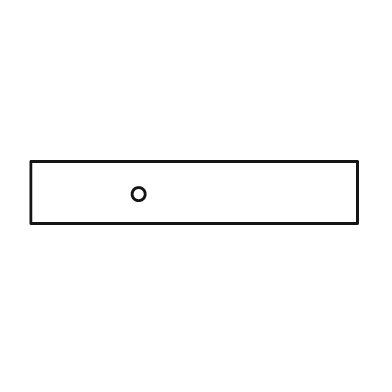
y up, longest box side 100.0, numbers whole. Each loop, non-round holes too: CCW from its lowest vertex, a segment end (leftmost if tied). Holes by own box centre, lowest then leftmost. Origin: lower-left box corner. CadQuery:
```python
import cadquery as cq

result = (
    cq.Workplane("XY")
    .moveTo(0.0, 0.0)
    .lineTo(100.0, 0.0)
    .lineTo(100.0, 19.0)
    .lineTo(0.0, 19.0)
    .close()
    .moveTo(33.0, 9.0)
    .circle(2.0)
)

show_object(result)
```